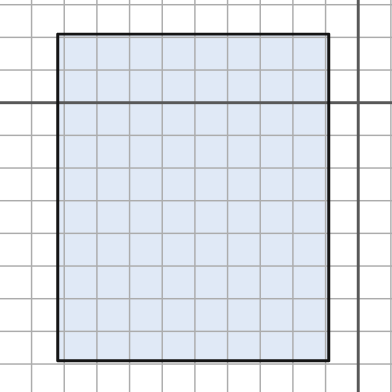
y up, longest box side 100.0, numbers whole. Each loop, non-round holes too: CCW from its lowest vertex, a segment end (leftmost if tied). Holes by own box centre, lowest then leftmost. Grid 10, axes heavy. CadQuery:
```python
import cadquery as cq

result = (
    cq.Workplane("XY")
    .moveTo(-92.0, -79.0)
    .lineTo(-9.0, -79.0)
    .lineTo(-9.0, 21.0)
    .lineTo(-92.0, 21.0)
    .close()
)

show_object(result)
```